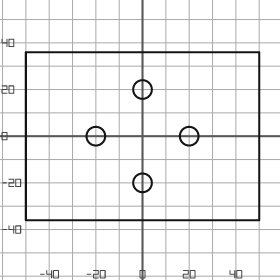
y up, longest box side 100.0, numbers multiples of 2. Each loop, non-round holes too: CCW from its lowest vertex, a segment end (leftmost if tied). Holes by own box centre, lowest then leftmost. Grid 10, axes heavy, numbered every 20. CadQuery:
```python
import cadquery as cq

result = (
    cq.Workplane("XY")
    .moveTo(-50.0, -36.0)
    .lineTo(50.0, -36.0)
    .lineTo(50.0, 36.0)
    .lineTo(-50.0, 36.0)
    .close()
    .moveTo(0.0, -20.0)
    .circle(4.0)
    .moveTo(-20.0, 0.0)
    .circle(4.0)
    .moveTo(20.0, 0.0)
    .circle(4.0)
    .moveTo(0.0, 20.0)
    .circle(4.0)
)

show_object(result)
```